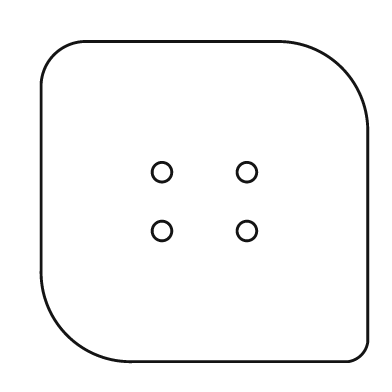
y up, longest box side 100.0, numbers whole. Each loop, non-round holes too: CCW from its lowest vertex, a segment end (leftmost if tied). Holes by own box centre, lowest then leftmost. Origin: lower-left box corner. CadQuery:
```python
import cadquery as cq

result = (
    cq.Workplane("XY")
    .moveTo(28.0, 0.0)
    .lineTo(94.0, 0.0)
    .threePointArc((98.0, 2.0), (100.0, 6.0))
    .lineTo(100.0, 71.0)
    .threePointArc((92.0, 90.0), (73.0, 98.0))
    .lineTo(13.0, 98.0)
    .threePointArc((4.0, 94.0), (0.0, 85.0))
    .lineTo(0.0, 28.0)
    .threePointArc((8.0, 8.0), (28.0, 0.0))
    .close()
    .moveTo(37.0, 40.0)
    .circle(3.0)
    .moveTo(63.0, 40.0)
    .circle(3.0)
    .moveTo(37.0, 58.0)
    .circle(3.0)
    .moveTo(63.0, 58.0)
    .circle(3.0)
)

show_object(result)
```